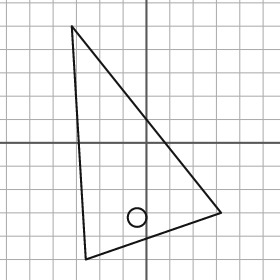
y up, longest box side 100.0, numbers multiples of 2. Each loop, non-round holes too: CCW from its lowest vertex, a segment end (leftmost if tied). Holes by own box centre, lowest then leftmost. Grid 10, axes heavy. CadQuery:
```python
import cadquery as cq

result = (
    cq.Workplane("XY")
    .moveTo(-26.0, -50.0)
    .lineTo(32.0, -30.0)
    .lineTo(-32.0, 50.0)
    .close()
    .moveTo(-4.0, -32.0)
    .circle(4.0)
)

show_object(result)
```